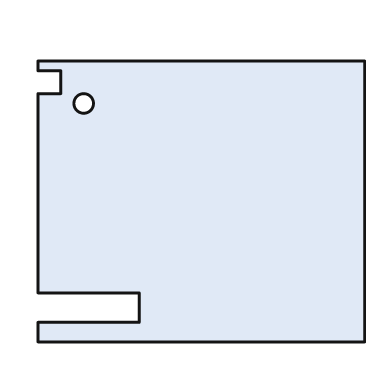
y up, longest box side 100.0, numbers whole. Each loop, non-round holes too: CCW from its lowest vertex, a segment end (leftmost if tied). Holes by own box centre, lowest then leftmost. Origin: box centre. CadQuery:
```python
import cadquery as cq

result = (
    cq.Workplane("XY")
    .moveTo(-50.0, -43.0)
    .lineTo(50.0, -43.0)
    .lineTo(50.0, 43.0)
    .lineTo(-50.0, 43.0)
    .lineTo(-50.0, 40.0)
    .lineTo(-43.0, 40.0)
    .lineTo(-43.0, 33.0)
    .lineTo(-50.0, 33.0)
    .lineTo(-50.0, -28.0)
    .lineTo(-19.0, -28.0)
    .lineTo(-19.0, -37.0)
    .lineTo(-50.0, -37.0)
    .close()
    .moveTo(-36.0, 30.0)
    .circle(3.0)
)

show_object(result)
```